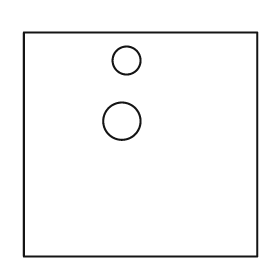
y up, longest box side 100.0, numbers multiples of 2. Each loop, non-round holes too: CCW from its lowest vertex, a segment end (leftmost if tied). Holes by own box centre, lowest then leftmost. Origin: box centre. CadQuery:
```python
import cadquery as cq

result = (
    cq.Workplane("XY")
    .moveTo(-50.0, -48.0)
    .lineTo(50.0, -48.0)
    .lineTo(50.0, 48.0)
    .lineTo(-50.0, 48.0)
    .close()
    .moveTo(-8.0, 10.0)
    .circle(8.0)
    .moveTo(-6.0, 36.0)
    .circle(6.0)
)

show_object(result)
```